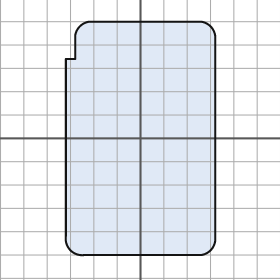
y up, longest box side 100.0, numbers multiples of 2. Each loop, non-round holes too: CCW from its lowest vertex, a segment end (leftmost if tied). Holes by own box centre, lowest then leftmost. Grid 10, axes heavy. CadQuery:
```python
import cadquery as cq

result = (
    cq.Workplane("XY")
    .moveTo(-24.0, -50.0)
    .lineTo(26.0, -50.0)
    .threePointArc((30.0, -48.0), (32.0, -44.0))
    .lineTo(32.0, 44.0)
    .threePointArc((30.0, 48.0), (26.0, 50.0))
    .lineTo(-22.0, 50.0)
    .threePointArc((-26.0, 48.0), (-28.0, 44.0))
    .lineTo(-28.0, 34.0)
    .lineTo(-32.0, 34.0)
    .lineTo(-32.0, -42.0)
    .threePointArc((-30.0, -48.0), (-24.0, -50.0))
    .close()
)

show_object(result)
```